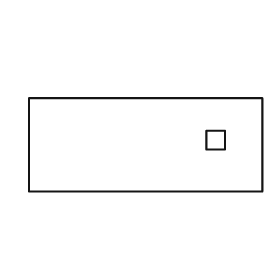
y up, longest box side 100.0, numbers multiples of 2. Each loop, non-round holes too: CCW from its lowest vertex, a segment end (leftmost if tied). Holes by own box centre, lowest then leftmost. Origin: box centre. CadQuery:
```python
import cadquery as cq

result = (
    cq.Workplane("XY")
    .moveTo(-50.0, -20.0)
    .lineTo(50.0, -20.0)
    .lineTo(50.0, 20.0)
    .lineTo(-50.0, 20.0)
    .close()
    .moveTo(26.0, -2.0)
    .lineTo(34.0, -2.0)
    .lineTo(34.0, 6.0)
    .lineTo(26.0, 6.0)
    .close()
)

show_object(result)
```